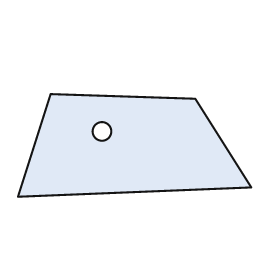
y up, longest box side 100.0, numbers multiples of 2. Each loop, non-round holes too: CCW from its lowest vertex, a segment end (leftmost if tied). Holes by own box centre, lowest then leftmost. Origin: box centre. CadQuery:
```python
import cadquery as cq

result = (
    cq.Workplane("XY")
    .moveTo(-50.0, -22.0)
    .lineTo(50.0, -18.0)
    .lineTo(26.0, 20.0)
    .lineTo(-36.0, 22.0)
    .close()
    .moveTo(-14.0, 6.0)
    .circle(4.0)
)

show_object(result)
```